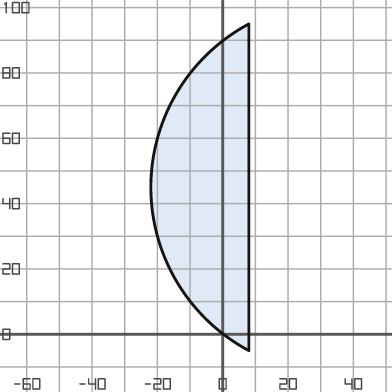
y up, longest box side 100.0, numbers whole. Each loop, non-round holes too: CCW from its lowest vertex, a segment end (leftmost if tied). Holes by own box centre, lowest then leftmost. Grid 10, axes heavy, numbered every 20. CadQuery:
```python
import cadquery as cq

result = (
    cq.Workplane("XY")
    .moveTo(8.0, -5.0)
    .lineTo(8.0, 95.0)
    .threePointArc((-22.0, 45.0), (8.0, -5.0))
    .close()
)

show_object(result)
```